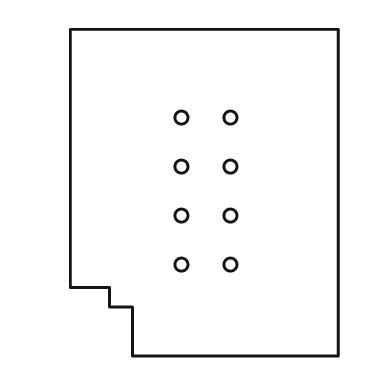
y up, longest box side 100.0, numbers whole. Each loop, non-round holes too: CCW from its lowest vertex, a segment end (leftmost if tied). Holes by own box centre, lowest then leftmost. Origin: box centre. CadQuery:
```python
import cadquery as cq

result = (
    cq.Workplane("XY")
    .moveTo(-22.0, -50.0)
    .lineTo(41.0, -50.0)
    .lineTo(41.0, 50.0)
    .lineTo(-41.0, 50.0)
    .lineTo(-41.0, -29.0)
    .lineTo(-29.0, -29.0)
    .lineTo(-29.0, -35.0)
    .lineTo(-22.0, -35.0)
    .close()
    .moveTo(-7.0, -22.0)
    .circle(2.0)
    .moveTo(8.0, -22.0)
    .circle(2.0)
    .moveTo(-7.0, -7.0)
    .circle(2.0)
    .moveTo(8.0, -7.0)
    .circle(2.0)
    .moveTo(-7.0, 8.0)
    .circle(2.0)
    .moveTo(8.0, 8.0)
    .circle(2.0)
    .moveTo(-7.0, 23.0)
    .circle(2.0)
    .moveTo(8.0, 23.0)
    .circle(2.0)
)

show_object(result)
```